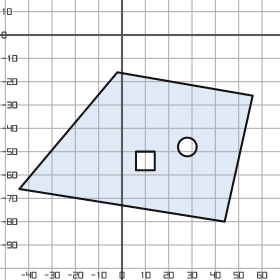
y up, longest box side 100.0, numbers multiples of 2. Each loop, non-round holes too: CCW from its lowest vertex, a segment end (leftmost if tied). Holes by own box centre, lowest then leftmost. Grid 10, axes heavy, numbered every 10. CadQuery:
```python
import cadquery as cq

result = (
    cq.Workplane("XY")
    .moveTo(44.0, -80.0)
    .lineTo(56.0, -26.0)
    .lineTo(-2.0, -16.0)
    .lineTo(-44.0, -66.0)
    .close()
    .moveTo(6.0, -58.0)
    .lineTo(14.0, -58.0)
    .lineTo(14.0, -50.0)
    .lineTo(6.0, -50.0)
    .close()
    .moveTo(28.0, -48.0)
    .circle(4.0)
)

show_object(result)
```